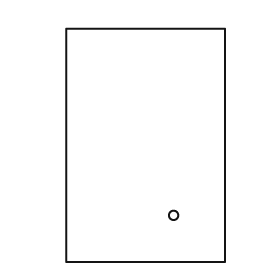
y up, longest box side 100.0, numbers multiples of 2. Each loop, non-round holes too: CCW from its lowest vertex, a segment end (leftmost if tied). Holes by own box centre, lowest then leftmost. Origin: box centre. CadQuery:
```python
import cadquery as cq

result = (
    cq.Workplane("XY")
    .moveTo(-34.0, -50.0)
    .lineTo(34.0, -50.0)
    .lineTo(34.0, 50.0)
    .lineTo(-34.0, 50.0)
    .close()
    .moveTo(12.0, -30.0)
    .circle(2.0)
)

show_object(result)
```